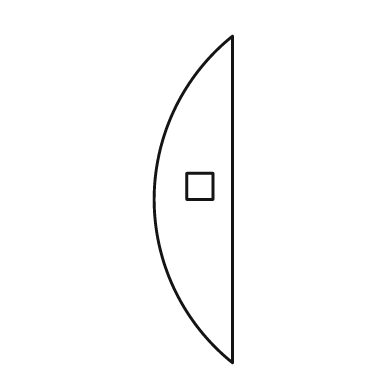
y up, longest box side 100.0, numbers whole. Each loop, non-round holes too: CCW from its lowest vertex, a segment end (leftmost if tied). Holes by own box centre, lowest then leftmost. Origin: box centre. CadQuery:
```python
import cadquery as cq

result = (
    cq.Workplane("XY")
    .moveTo(12.0, -50.0)
    .lineTo(12.0, 50.0)
    .threePointArc((-12.0, 0.0), (12.0, -50.0))
    .close()
    .moveTo(-2.0, 0.0)
    .lineTo(6.0, 0.0)
    .lineTo(6.0, 8.0)
    .lineTo(-2.0, 8.0)
    .close()
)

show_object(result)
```